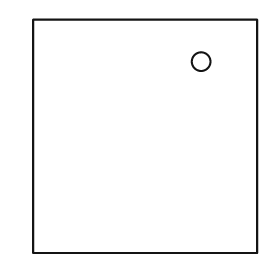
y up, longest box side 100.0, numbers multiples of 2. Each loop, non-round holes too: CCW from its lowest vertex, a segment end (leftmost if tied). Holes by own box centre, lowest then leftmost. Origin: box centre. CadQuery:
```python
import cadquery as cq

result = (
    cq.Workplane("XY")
    .moveTo(-48.0, -50.0)
    .lineTo(48.0, -50.0)
    .lineTo(48.0, 50.0)
    .lineTo(-48.0, 50.0)
    .close()
    .moveTo(24.0, 32.0)
    .circle(4.0)
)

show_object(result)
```